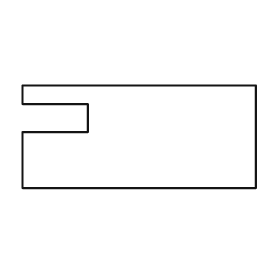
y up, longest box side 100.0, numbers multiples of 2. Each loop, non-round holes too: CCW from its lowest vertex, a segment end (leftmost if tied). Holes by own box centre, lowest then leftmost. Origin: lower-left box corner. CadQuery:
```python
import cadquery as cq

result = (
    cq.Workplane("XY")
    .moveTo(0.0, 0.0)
    .lineTo(100.0, 0.0)
    .lineTo(100.0, 44.0)
    .lineTo(0.0, 44.0)
    .lineTo(0.0, 36.0)
    .lineTo(28.0, 36.0)
    .lineTo(28.0, 24.0)
    .lineTo(0.0, 24.0)
    .close()
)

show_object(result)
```